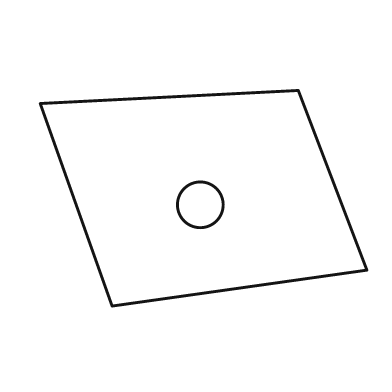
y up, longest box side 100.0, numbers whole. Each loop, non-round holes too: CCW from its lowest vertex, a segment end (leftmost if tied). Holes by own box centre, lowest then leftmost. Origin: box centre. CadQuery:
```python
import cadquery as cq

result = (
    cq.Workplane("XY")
    .moveTo(-28.0, -33.0)
    .lineTo(50.0, -22.0)
    .lineTo(29.0, 33.0)
    .lineTo(-50.0, 29.0)
    .close()
    .moveTo(-1.0, -2.0)
    .circle(7.0)
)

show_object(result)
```